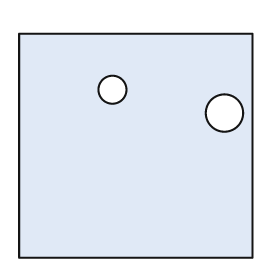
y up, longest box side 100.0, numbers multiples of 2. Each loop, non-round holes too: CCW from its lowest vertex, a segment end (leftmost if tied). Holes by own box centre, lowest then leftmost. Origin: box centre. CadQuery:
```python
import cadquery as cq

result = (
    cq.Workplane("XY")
    .moveTo(-50.0, -48.0)
    .lineTo(50.0, -48.0)
    .lineTo(50.0, 48.0)
    .lineTo(-50.0, 48.0)
    .close()
    .moveTo(38.0, 14.0)
    .circle(8.0)
    .moveTo(-10.0, 24.0)
    .circle(6.0)
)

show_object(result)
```